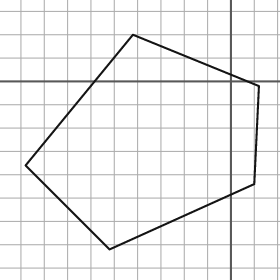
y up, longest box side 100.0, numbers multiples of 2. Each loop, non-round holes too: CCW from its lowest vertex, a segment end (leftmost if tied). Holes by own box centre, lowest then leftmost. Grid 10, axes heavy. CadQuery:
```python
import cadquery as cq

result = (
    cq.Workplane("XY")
    .moveTo(-52.0, -72.0)
    .lineTo(10.0, -44.0)
    .lineTo(12.0, -2.0)
    .lineTo(-42.0, 20.0)
    .lineTo(-88.0, -36.0)
    .close()
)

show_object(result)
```